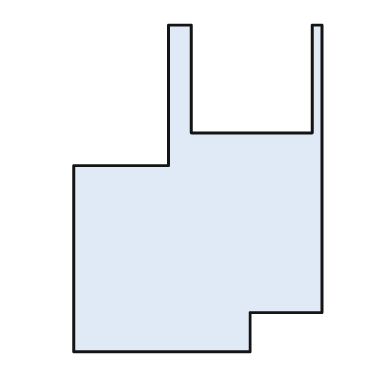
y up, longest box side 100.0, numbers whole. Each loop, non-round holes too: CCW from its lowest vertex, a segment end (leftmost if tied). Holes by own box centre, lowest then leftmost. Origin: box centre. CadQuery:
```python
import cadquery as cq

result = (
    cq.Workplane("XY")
    .moveTo(-38.0, -50.0)
    .lineTo(16.0, -50.0)
    .lineTo(16.0, -38.0)
    .lineTo(38.0, -38.0)
    .lineTo(38.0, 50.0)
    .lineTo(35.0, 50.0)
    .lineTo(35.0, 17.0)
    .lineTo(-2.0, 17.0)
    .lineTo(-2.0, 50.0)
    .lineTo(-9.0, 50.0)
    .lineTo(-9.0, 7.0)
    .lineTo(-38.0, 7.0)
    .close()
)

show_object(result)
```